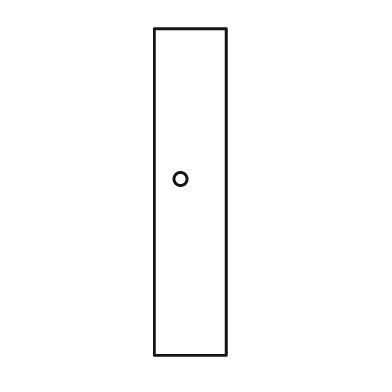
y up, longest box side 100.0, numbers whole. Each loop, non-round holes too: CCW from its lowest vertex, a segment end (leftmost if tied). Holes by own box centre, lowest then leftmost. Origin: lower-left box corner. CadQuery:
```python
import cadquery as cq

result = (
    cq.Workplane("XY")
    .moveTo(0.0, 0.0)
    .lineTo(22.0, 0.0)
    .lineTo(22.0, 100.0)
    .lineTo(0.0, 100.0)
    .close()
    .moveTo(8.0, 54.0)
    .circle(2.0)
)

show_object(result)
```